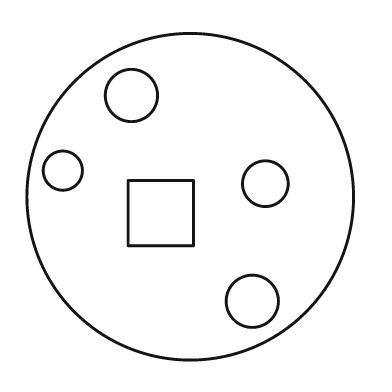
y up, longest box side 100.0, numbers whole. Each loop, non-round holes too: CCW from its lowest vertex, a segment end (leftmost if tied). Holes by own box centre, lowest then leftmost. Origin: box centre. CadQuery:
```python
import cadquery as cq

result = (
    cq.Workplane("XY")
    .moveTo(0.0, 0.0)
    .circle(50.0)
    .moveTo(19.0, -32.0)
    .circle(8.0)
    .moveTo(-19.0, -15.0)
    .lineTo(1.0, -15.0)
    .lineTo(1.0, 5.0)
    .lineTo(-19.0, 5.0)
    .close()
    .moveTo(23.0, 4.0)
    .circle(7.0)
    .moveTo(-39.0, 8.0)
    .circle(6.0)
    .moveTo(-18.0, 31.0)
    .circle(8.0)
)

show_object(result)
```